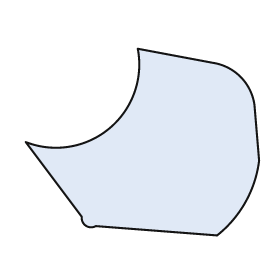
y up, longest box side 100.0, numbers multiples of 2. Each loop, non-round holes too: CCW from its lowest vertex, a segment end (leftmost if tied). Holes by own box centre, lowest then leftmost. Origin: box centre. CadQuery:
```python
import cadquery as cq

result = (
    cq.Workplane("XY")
    .moveTo(32.0, -40.0)
    .threePointArc((44.0, -26.0), (50.0, -8.0))
    .lineTo(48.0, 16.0)
    .threePointArc((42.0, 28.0), (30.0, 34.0))
    .lineTo(-2.0, 40.0)
    .threePointArc((-14.0, 6.0), (-50.0, 0.0))
    .lineTo(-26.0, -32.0)
    .threePointArc((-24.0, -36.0), (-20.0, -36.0))
    .close()
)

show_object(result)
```